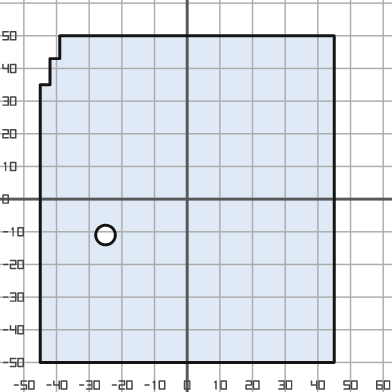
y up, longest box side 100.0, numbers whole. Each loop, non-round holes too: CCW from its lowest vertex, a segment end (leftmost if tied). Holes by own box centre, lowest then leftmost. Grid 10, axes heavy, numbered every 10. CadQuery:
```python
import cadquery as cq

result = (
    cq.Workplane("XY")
    .moveTo(-45.0, -50.0)
    .lineTo(45.0, -50.0)
    .lineTo(45.0, 50.0)
    .lineTo(-39.0, 50.0)
    .lineTo(-39.0, 43.0)
    .lineTo(-42.0, 43.0)
    .lineTo(-42.0, 35.0)
    .lineTo(-45.0, 35.0)
    .close()
    .moveTo(-25.0, -11.0)
    .circle(3.0)
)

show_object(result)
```